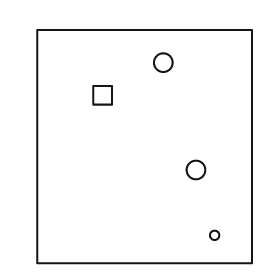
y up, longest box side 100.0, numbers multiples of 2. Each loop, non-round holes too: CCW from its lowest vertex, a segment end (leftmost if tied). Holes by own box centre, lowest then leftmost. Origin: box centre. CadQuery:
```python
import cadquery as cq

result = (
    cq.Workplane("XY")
    .moveTo(-46.0, -50.0)
    .lineTo(46.0, -50.0)
    .lineTo(46.0, 50.0)
    .lineTo(-46.0, 50.0)
    .close()
    .moveTo(30.0, -38.0)
    .circle(2.0)
    .moveTo(22.0, -10.0)
    .circle(4.0)
    .moveTo(-22.0, 18.0)
    .lineTo(-14.0, 18.0)
    .lineTo(-14.0, 26.0)
    .lineTo(-22.0, 26.0)
    .close()
    .moveTo(8.0, 36.0)
    .circle(4.0)
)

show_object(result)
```